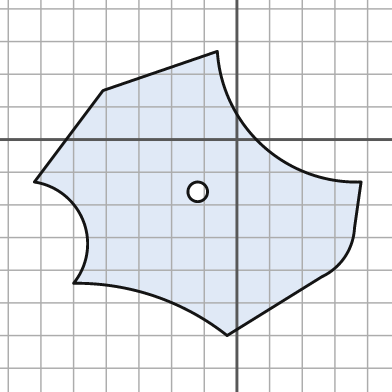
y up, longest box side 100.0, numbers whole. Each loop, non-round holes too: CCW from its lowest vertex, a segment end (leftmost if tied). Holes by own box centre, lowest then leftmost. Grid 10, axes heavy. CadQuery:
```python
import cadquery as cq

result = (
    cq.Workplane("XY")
    .moveTo(-3.0, -60.0)
    .lineTo(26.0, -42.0)
    .threePointArc((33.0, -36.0), (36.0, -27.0))
    .lineTo(38.0, -13.0)
    .threePointArc((8.0, -2.0), (-6.0, 27.0))
    .lineTo(-41.0, 15.0)
    .lineTo(-62.0, -13.0)
    .threePointArc((-47.0, -25.0), (-50.0, -44.0))
    .threePointArc((-25.0, -48.0), (-3.0, -60.0))
    .close()
    .moveTo(-12.0, -16.0)
    .circle(3.0)
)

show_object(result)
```